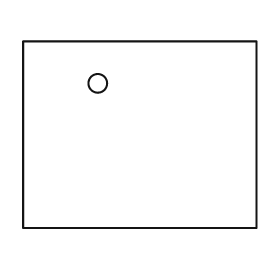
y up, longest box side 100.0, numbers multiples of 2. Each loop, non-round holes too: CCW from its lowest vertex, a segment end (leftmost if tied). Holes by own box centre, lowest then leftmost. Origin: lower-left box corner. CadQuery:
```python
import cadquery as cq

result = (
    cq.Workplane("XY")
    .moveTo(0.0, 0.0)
    .lineTo(100.0, 0.0)
    .lineTo(100.0, 80.0)
    .lineTo(0.0, 80.0)
    .close()
    .moveTo(32.0, 62.0)
    .circle(4.0)
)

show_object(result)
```